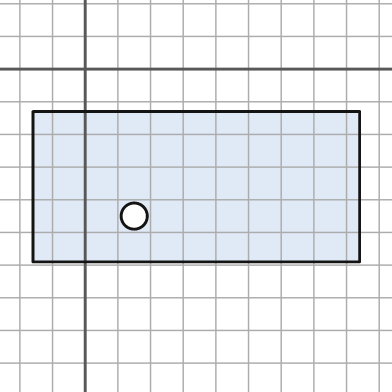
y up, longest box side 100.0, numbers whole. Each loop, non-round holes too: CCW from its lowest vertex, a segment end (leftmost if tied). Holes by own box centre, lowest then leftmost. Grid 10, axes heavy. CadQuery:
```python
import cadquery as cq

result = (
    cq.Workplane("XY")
    .moveTo(-16.0, -59.0)
    .lineTo(84.0, -59.0)
    .lineTo(84.0, -13.0)
    .lineTo(-16.0, -13.0)
    .close()
    .moveTo(15.0, -45.0)
    .circle(4.0)
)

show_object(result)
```